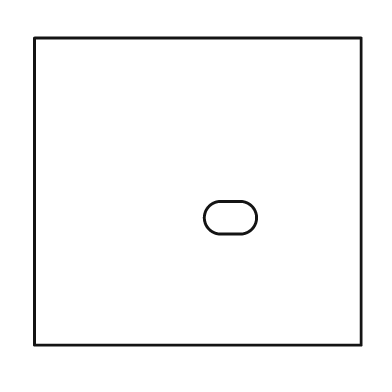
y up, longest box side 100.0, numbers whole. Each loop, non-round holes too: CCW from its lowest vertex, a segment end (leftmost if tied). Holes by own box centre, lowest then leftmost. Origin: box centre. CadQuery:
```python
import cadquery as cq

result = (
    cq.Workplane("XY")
    .moveTo(-50.0, -47.0)
    .lineTo(50.0, -47.0)
    .lineTo(50.0, 47.0)
    .lineTo(-50.0, 47.0)
    .close()
    .moveTo(7.0, -13.0)
    .lineTo(13.0, -13.0)
    .threePointArc((18.0, -8.0), (13.0, -3.0))
    .lineTo(7.0, -3.0)
    .threePointArc((2.0, -8.0), (7.0, -13.0))
    .close()
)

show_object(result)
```